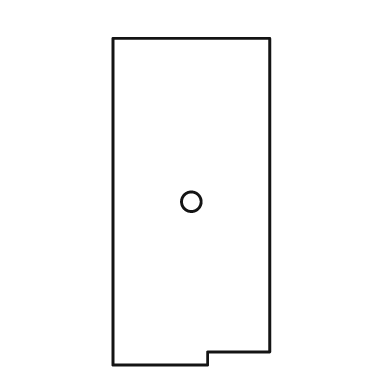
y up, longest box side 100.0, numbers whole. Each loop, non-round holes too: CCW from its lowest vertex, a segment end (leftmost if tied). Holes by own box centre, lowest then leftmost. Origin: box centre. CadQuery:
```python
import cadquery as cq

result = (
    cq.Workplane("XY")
    .moveTo(-24.0, -50.0)
    .lineTo(5.0, -50.0)
    .lineTo(5.0, -46.0)
    .lineTo(24.0, -46.0)
    .lineTo(24.0, 50.0)
    .lineTo(-24.0, 50.0)
    .close()
    .moveTo(0.0, 0.0)
    .circle(3.0)
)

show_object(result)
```